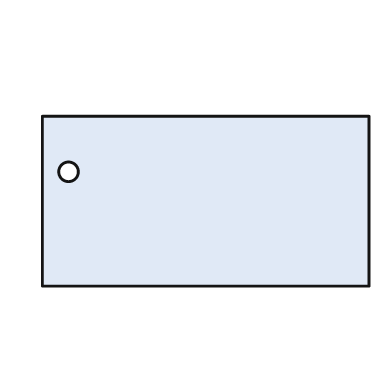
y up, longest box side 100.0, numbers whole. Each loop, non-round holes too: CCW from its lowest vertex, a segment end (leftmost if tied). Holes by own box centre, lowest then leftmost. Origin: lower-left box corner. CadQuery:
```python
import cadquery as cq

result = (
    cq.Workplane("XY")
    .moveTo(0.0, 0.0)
    .lineTo(100.0, 0.0)
    .lineTo(100.0, 52.0)
    .lineTo(0.0, 52.0)
    .close()
    .moveTo(8.0, 35.0)
    .circle(3.0)
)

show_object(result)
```